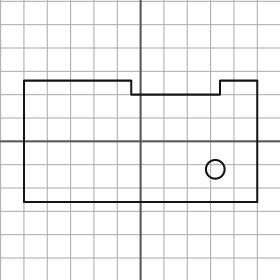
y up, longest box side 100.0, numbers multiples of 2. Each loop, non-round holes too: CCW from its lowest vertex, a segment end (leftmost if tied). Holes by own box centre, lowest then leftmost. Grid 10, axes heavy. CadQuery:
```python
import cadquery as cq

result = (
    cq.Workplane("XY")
    .moveTo(-50.0, -26.0)
    .lineTo(50.0, -26.0)
    .lineTo(50.0, 26.0)
    .lineTo(34.0, 26.0)
    .lineTo(34.0, 20.0)
    .lineTo(-4.0, 20.0)
    .lineTo(-4.0, 26.0)
    .lineTo(-50.0, 26.0)
    .close()
    .moveTo(32.0, -12.0)
    .circle(4.0)
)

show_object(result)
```